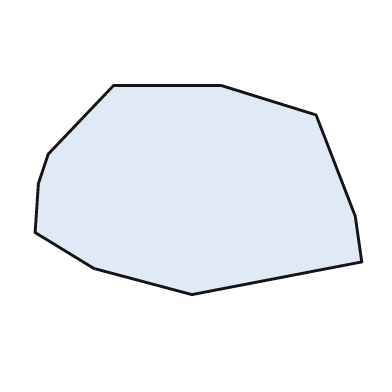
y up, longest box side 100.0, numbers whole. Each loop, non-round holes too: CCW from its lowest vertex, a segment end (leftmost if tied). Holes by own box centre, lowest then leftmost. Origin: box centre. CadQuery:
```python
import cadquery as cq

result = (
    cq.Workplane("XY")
    .moveTo(-2.0, -32.0)
    .lineTo(50.0, -22.0)
    .lineTo(48.0, -8.0)
    .lineTo(36.0, 23.0)
    .lineTo(7.0, 32.0)
    .lineTo(-26.0, 32.0)
    .lineTo(-46.0, 11.0)
    .lineTo(-49.0, 2.0)
    .lineTo(-50.0, -13.0)
    .lineTo(-32.0, -24.0)
    .close()
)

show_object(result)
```